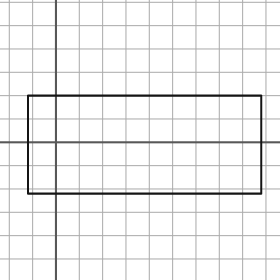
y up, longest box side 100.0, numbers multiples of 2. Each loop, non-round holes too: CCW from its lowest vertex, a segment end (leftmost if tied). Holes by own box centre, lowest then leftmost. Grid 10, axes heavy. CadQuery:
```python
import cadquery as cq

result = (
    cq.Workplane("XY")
    .moveTo(-12.0, -22.0)
    .lineTo(88.0, -22.0)
    .lineTo(88.0, 20.0)
    .lineTo(-12.0, 20.0)
    .close()
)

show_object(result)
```